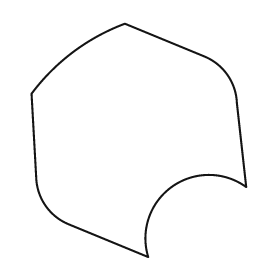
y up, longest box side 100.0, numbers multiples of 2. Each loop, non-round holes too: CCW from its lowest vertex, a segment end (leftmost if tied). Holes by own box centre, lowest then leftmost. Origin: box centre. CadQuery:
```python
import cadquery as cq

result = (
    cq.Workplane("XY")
    .moveTo(4.0, -50.0)
    .threePointArc((14.0, -20.0), (46.0, -20.0))
    .lineTo(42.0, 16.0)
    .threePointArc((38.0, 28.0), (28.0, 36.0))
    .lineTo(-6.0, 50.0)
    .threePointArc((-28.0, 38.0), (-46.0, 20.0))
    .lineTo(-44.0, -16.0)
    .threePointArc((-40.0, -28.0), (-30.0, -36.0))
    .close()
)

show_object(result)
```